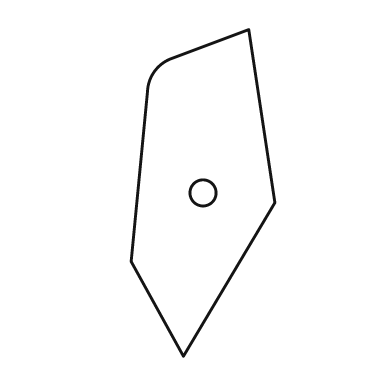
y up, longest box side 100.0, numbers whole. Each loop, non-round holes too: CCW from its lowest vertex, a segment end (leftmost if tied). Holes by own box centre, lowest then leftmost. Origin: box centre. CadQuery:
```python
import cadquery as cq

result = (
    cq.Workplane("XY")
    .moveTo(-6.0, -50.0)
    .lineTo(22.0, -3.0)
    .lineTo(14.0, 50.0)
    .lineTo(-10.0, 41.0)
    .threePointArc((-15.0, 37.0), (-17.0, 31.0))
    .lineTo(-22.0, -21.0)
    .close()
    .moveTo(0.0, 0.0)
    .circle(4.0)
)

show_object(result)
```